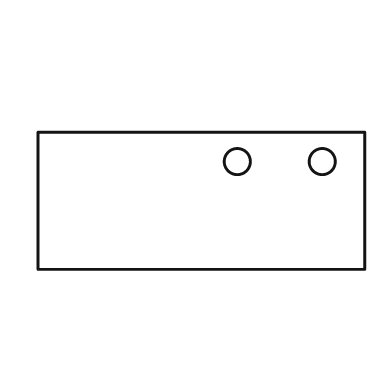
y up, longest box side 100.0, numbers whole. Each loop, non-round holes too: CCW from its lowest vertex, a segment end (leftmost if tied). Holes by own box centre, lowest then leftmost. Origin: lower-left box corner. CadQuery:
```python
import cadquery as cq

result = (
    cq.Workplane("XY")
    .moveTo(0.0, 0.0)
    .lineTo(100.0, 0.0)
    .lineTo(100.0, 42.0)
    .lineTo(0.0, 42.0)
    .close()
    .moveTo(61.0, 33.0)
    .circle(4.0)
    .moveTo(87.0, 33.0)
    .circle(4.0)
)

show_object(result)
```